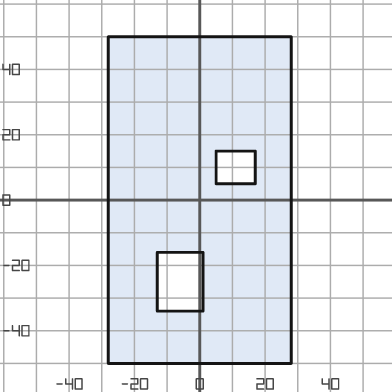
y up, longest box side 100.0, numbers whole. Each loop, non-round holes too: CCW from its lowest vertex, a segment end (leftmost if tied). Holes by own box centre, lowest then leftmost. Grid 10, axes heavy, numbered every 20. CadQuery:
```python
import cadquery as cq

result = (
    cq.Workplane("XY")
    .moveTo(-28.0, -50.0)
    .lineTo(28.0, -50.0)
    .lineTo(28.0, 50.0)
    .lineTo(-28.0, 50.0)
    .close()
    .moveTo(-13.0, -34.0)
    .lineTo(1.0, -34.0)
    .lineTo(1.0, -16.0)
    .lineTo(-13.0, -16.0)
    .close()
    .moveTo(5.0, 5.0)
    .lineTo(17.0, 5.0)
    .lineTo(17.0, 15.0)
    .lineTo(5.0, 15.0)
    .close()
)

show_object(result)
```